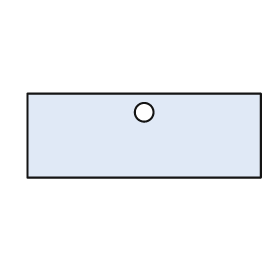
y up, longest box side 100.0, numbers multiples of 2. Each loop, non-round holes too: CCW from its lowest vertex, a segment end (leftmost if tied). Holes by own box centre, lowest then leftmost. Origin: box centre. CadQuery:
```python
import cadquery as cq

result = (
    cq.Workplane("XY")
    .moveTo(-50.0, -18.0)
    .lineTo(50.0, -18.0)
    .lineTo(50.0, 18.0)
    .lineTo(-50.0, 18.0)
    .close()
    .moveTo(0.0, 10.0)
    .circle(4.0)
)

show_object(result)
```